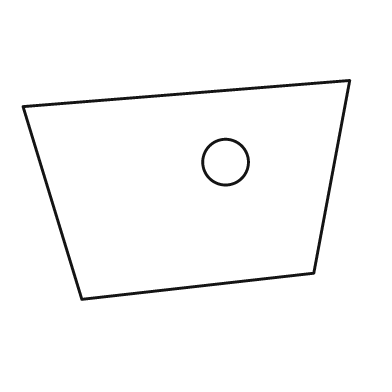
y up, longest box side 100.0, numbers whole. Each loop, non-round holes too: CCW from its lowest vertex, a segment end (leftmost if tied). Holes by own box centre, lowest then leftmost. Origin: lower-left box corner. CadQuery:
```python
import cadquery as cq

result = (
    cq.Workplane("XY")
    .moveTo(18.0, 0.0)
    .lineTo(89.0, 8.0)
    .lineTo(100.0, 67.0)
    .lineTo(0.0, 59.0)
    .close()
    .moveTo(62.0, 42.0)
    .circle(7.0)
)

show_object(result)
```